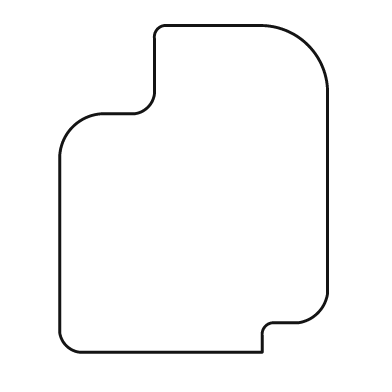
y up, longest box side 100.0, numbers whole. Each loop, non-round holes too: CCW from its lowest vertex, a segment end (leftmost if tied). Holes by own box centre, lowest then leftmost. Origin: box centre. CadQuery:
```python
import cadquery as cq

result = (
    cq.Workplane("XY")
    .moveTo(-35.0, -50.0)
    .lineTo(21.0, -50.0)
    .lineTo(21.0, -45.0)
    .threePointArc((22.0, -42.0), (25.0, -41.0))
    .lineTo(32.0, -41.0)
    .threePointArc((38.0, -38.0), (41.0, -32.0))
    .lineTo(41.0, 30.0)
    .threePointArc((35.0, 44.0), (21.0, 50.0))
    .lineTo(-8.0, 50.0)
    .threePointArc((-11.0, 49.0), (-12.0, 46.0))
    .lineTo(-12.0, 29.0)
    .threePointArc((-14.0, 25.0), (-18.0, 23.0))
    .lineTo(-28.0, 23.0)
    .threePointArc((-37.0, 19.0), (-41.0, 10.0))
    .lineTo(-41.0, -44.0)
    .threePointArc((-39.0, -48.0), (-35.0, -50.0))
    .close()
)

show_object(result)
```